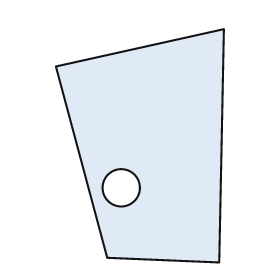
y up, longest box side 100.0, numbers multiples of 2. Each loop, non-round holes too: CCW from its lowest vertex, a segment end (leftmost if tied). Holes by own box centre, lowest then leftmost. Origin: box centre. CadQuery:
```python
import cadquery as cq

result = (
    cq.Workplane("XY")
    .moveTo(34.0, -50.0)
    .lineTo(36.0, 50.0)
    .lineTo(-36.0, 34.0)
    .lineTo(-14.0, -48.0)
    .close()
    .moveTo(-8.0, -18.0)
    .circle(8.0)
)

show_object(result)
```